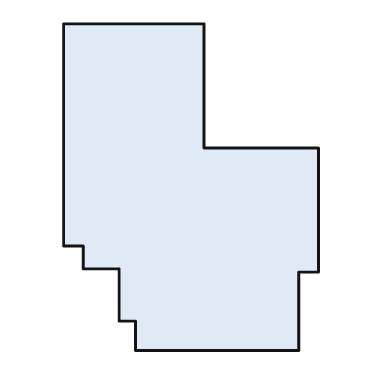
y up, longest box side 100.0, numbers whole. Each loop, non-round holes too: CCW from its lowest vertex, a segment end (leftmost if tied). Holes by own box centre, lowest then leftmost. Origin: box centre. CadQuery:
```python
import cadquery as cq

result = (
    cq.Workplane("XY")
    .moveTo(-17.0, -50.0)
    .lineTo(33.0, -50.0)
    .lineTo(33.0, -26.0)
    .lineTo(39.0, -26.0)
    .lineTo(39.0, 12.0)
    .lineTo(4.0, 12.0)
    .lineTo(4.0, 50.0)
    .lineTo(-39.0, 50.0)
    .lineTo(-39.0, -18.0)
    .lineTo(-33.0, -18.0)
    .lineTo(-33.0, -25.0)
    .lineTo(-22.0, -25.0)
    .lineTo(-22.0, -41.0)
    .lineTo(-17.0, -41.0)
    .close()
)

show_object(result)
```